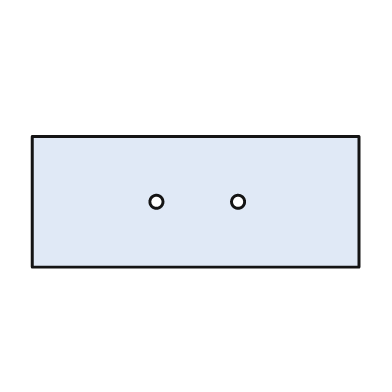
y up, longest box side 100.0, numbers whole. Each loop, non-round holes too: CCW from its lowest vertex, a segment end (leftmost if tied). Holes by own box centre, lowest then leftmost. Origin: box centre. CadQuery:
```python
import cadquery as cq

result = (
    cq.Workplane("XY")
    .moveTo(-50.0, -20.0)
    .lineTo(50.0, -20.0)
    .lineTo(50.0, 20.0)
    .lineTo(-50.0, 20.0)
    .close()
    .moveTo(-12.0, 0.0)
    .circle(2.0)
    .moveTo(13.0, 0.0)
    .circle(2.0)
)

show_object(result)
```